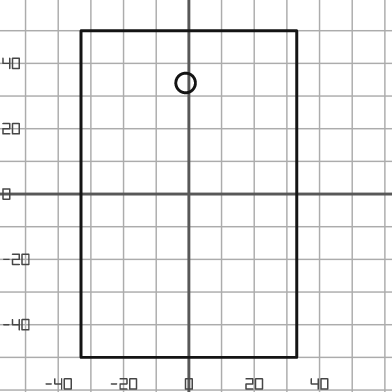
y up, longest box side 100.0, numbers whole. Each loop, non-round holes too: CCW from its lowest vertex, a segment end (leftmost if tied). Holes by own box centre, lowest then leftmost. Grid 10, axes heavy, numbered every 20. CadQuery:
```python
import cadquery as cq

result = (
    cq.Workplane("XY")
    .moveTo(-33.0, -50.0)
    .lineTo(33.0, -50.0)
    .lineTo(33.0, 50.0)
    .lineTo(-33.0, 50.0)
    .close()
    .moveTo(-1.0, 34.0)
    .circle(3.0)
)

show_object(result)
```